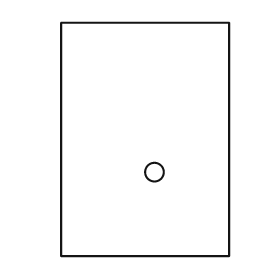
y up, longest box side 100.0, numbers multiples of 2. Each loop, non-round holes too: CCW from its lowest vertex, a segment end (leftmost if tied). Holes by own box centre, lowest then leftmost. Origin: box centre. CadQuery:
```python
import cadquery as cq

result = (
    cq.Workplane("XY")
    .moveTo(-36.0, -50.0)
    .lineTo(36.0, -50.0)
    .lineTo(36.0, 50.0)
    .lineTo(-36.0, 50.0)
    .close()
    .moveTo(4.0, -14.0)
    .circle(4.0)
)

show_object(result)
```